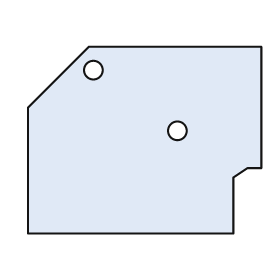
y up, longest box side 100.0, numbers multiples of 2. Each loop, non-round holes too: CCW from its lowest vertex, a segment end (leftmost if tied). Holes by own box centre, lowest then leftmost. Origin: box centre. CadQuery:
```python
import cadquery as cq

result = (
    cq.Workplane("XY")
    .moveTo(-50.0, -40.0)
    .lineTo(38.0, -40.0)
    .lineTo(38.0, -16.0)
    .lineTo(44.0, -12.0)
    .lineTo(50.0, -12.0)
    .lineTo(50.0, 40.0)
    .lineTo(-24.0, 40.0)
    .lineTo(-50.0, 14.0)
    .close()
    .moveTo(14.0, 4.0)
    .circle(4.0)
    .moveTo(-22.0, 30.0)
    .circle(4.0)
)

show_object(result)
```